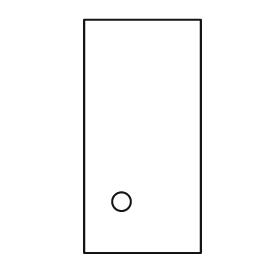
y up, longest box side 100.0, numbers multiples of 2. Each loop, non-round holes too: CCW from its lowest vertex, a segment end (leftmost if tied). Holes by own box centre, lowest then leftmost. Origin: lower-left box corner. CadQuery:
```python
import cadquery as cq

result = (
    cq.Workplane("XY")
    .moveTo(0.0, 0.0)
    .lineTo(50.0, 0.0)
    .lineTo(50.0, 100.0)
    .lineTo(0.0, 100.0)
    .close()
    .moveTo(16.0, 22.0)
    .circle(4.0)
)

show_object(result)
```